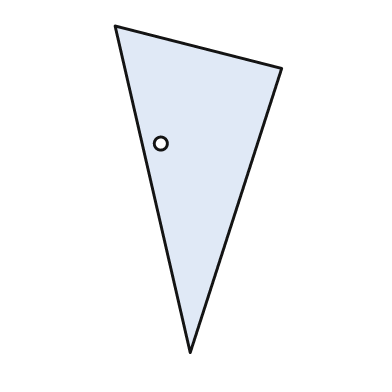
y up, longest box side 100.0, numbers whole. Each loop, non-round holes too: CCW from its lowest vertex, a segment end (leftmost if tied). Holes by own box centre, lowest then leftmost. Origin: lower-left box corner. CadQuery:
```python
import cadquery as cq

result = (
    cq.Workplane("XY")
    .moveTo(23.0, 0.0)
    .lineTo(51.0, 87.0)
    .lineTo(0.0, 100.0)
    .close()
    .moveTo(14.0, 64.0)
    .circle(2.0)
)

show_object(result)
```